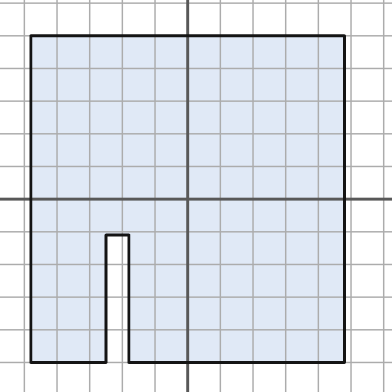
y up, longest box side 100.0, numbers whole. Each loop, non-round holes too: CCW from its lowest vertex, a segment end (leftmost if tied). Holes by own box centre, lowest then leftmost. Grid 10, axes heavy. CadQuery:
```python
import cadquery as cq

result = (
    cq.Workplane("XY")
    .moveTo(-48.0, -50.0)
    .lineTo(-25.0, -50.0)
    .lineTo(-25.0, -11.0)
    .lineTo(-18.0, -11.0)
    .lineTo(-18.0, -50.0)
    .lineTo(48.0, -50.0)
    .lineTo(48.0, 50.0)
    .lineTo(-48.0, 50.0)
    .close()
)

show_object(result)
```